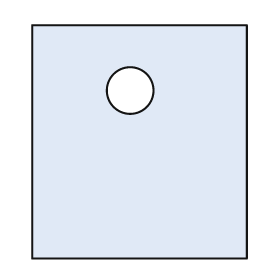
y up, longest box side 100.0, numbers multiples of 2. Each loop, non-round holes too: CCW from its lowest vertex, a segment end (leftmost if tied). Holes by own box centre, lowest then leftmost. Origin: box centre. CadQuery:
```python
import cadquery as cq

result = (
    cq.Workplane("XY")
    .moveTo(-46.0, -50.0)
    .lineTo(46.0, -50.0)
    .lineTo(46.0, 50.0)
    .lineTo(-46.0, 50.0)
    .close()
    .moveTo(-4.0, 22.0)
    .circle(10.0)
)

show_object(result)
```